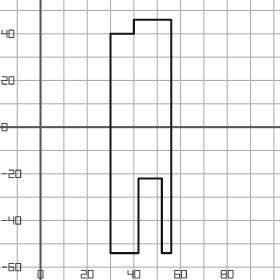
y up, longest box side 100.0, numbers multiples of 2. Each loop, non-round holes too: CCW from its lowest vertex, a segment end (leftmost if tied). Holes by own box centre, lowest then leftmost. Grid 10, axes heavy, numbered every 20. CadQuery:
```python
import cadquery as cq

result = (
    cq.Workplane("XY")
    .moveTo(30.0, -54.0)
    .lineTo(42.0, -54.0)
    .lineTo(42.0, -22.0)
    .lineTo(52.0, -22.0)
    .lineTo(52.0, -54.0)
    .lineTo(56.0, -54.0)
    .lineTo(56.0, 46.0)
    .lineTo(40.0, 46.0)
    .lineTo(40.0, 40.0)
    .lineTo(30.0, 40.0)
    .close()
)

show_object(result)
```